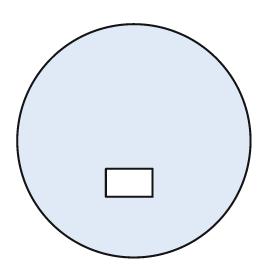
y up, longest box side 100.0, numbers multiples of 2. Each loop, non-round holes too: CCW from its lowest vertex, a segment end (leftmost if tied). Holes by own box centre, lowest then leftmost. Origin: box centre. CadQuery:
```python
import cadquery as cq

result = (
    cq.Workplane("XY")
    .moveTo(0.0, 0.0)
    .circle(50.0)
    .moveTo(-12.0, -24.0)
    .lineTo(8.0, -24.0)
    .lineTo(8.0, -12.0)
    .lineTo(-12.0, -12.0)
    .close()
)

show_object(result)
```